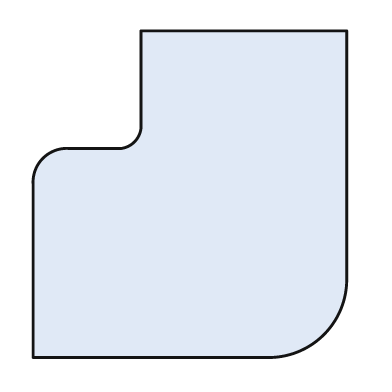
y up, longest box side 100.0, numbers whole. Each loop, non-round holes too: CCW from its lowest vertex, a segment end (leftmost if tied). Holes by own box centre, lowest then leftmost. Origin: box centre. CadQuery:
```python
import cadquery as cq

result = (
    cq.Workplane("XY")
    .moveTo(-48.0, -50.0)
    .lineTo(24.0, -50.0)
    .threePointArc((41.0, -43.0), (48.0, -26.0))
    .lineTo(48.0, 50.0)
    .lineTo(-15.0, 50.0)
    .lineTo(-15.0, 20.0)
    .threePointArc((-17.0, 16.0), (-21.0, 14.0))
    .lineTo(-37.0, 14.0)
    .threePointArc((-45.0, 11.0), (-48.0, 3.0))
    .close()
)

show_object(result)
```